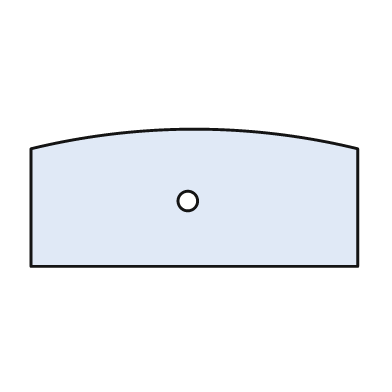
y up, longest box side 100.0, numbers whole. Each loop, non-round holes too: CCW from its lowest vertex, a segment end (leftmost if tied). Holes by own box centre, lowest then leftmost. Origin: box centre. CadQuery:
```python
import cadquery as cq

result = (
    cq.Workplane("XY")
    .moveTo(-50.0, -21.0)
    .lineTo(50.0, -21.0)
    .lineTo(50.0, 15.0)
    .threePointArc((0.0, 21.0), (-50.0, 15.0))
    .close()
    .moveTo(-2.0, -1.0)
    .circle(3.0)
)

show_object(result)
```